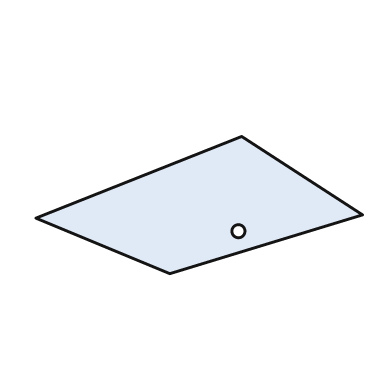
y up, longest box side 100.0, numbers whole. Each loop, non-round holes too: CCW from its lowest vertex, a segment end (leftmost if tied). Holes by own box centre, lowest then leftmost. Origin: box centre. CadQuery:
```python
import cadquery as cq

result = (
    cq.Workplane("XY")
    .moveTo(-9.0, -21.0)
    .lineTo(50.0, -3.0)
    .lineTo(13.0, 21.0)
    .lineTo(-50.0, -4.0)
    .close()
    .moveTo(12.0, -8.0)
    .circle(2.0)
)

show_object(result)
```